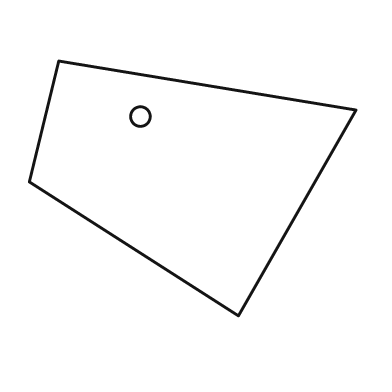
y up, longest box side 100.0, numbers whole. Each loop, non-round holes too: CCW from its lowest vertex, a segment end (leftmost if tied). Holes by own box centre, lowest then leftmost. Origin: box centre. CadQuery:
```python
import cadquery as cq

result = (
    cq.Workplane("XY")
    .moveTo(14.0, -39.0)
    .lineTo(50.0, 24.0)
    .lineTo(-41.0, 39.0)
    .lineTo(-50.0, 2.0)
    .close()
    .moveTo(-16.0, 22.0)
    .circle(3.0)
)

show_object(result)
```